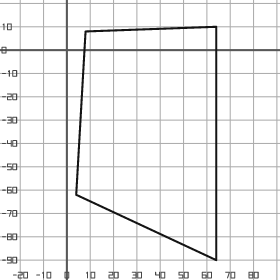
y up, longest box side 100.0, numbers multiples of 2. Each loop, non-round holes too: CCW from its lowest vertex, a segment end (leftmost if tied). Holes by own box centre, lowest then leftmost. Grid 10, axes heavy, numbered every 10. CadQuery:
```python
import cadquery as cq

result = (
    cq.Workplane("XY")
    .moveTo(64.0, -90.0)
    .lineTo(64.0, 10.0)
    .lineTo(8.0, 8.0)
    .lineTo(4.0, -62.0)
    .close()
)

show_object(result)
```